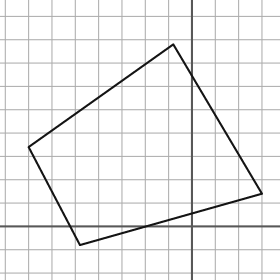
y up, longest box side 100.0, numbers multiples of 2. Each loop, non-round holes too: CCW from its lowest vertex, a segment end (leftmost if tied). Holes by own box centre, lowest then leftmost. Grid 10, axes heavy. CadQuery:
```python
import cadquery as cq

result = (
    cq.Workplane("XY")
    .moveTo(-48.0, -8.0)
    .lineTo(30.0, 14.0)
    .lineTo(-8.0, 78.0)
    .lineTo(-70.0, 34.0)
    .close()
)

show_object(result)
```